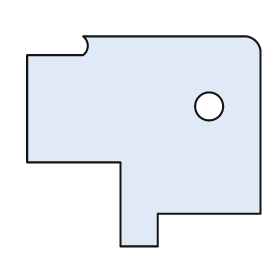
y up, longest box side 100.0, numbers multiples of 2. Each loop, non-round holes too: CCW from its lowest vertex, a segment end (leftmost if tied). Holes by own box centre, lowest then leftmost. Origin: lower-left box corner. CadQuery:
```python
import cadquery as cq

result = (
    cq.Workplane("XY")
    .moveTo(40.0, 0.0)
    .lineTo(56.0, 0.0)
    .lineTo(56.0, 14.0)
    .lineTo(100.0, 14.0)
    .lineTo(100.0, 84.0)
    .threePointArc((98.0, 88.0), (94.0, 90.0))
    .lineTo(24.0, 90.0)
    .threePointArc((26.0, 86.0), (24.0, 82.0))
    .lineTo(0.0, 82.0)
    .lineTo(0.0, 36.0)
    .lineTo(40.0, 36.0)
    .close()
    .moveTo(78.0, 60.0)
    .circle(6.0)
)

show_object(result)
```